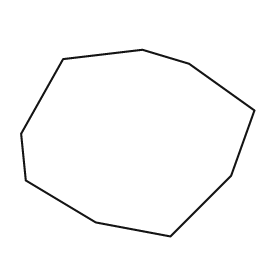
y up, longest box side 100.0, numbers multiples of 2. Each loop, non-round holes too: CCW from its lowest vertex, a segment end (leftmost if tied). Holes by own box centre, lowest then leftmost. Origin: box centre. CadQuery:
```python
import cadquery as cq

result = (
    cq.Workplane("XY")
    .moveTo(14.0, -40.0)
    .lineTo(40.0, -14.0)
    .lineTo(50.0, 14.0)
    .lineTo(22.0, 34.0)
    .lineTo(2.0, 40.0)
    .lineTo(-32.0, 36.0)
    .lineTo(-50.0, 4.0)
    .lineTo(-48.0, -16.0)
    .lineTo(-18.0, -34.0)
    .close()
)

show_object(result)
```